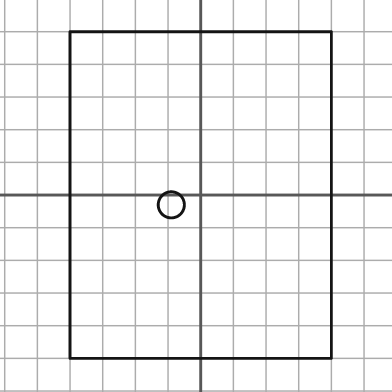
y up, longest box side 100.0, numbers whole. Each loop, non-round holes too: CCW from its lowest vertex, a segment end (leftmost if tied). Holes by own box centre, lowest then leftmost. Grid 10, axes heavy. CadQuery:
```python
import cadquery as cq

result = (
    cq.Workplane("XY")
    .moveTo(-40.0, -50.0)
    .lineTo(40.0, -50.0)
    .lineTo(40.0, 50.0)
    .lineTo(-40.0, 50.0)
    .close()
    .moveTo(-9.0, -3.0)
    .circle(4.0)
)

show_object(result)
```